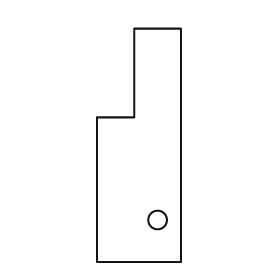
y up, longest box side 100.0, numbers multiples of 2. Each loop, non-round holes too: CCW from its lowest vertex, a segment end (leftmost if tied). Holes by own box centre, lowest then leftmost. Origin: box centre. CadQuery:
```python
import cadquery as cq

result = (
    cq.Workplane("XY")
    .moveTo(-18.0, -50.0)
    .lineTo(18.0, -50.0)
    .lineTo(18.0, 50.0)
    .lineTo(-2.0, 50.0)
    .lineTo(-2.0, 12.0)
    .lineTo(-18.0, 12.0)
    .close()
    .moveTo(8.0, -32.0)
    .circle(4.0)
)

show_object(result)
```